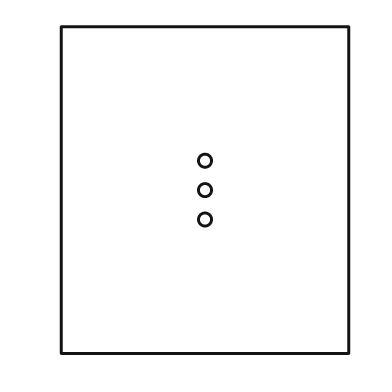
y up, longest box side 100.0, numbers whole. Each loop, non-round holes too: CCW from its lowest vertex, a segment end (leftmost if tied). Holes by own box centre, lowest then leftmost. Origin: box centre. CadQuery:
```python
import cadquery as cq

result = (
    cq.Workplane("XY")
    .moveTo(-44.0, -50.0)
    .lineTo(44.0, -50.0)
    .lineTo(44.0, 50.0)
    .lineTo(-44.0, 50.0)
    .close()
    .moveTo(0.0, -9.0)
    .circle(2.0)
    .moveTo(0.0, 0.0)
    .circle(2.0)
    .moveTo(0.0, 9.0)
    .circle(2.0)
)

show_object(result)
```